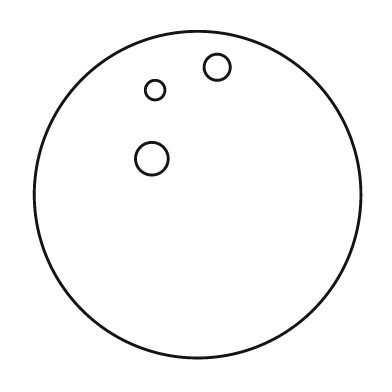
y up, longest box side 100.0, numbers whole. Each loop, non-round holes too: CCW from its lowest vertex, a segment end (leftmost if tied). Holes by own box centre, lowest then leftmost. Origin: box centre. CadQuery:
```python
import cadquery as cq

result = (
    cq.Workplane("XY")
    .moveTo(0.0, 0.0)
    .circle(50.0)
    .moveTo(-14.0, 11.0)
    .circle(5.0)
    .moveTo(-13.0, 32.0)
    .circle(3.0)
    .moveTo(6.0, 39.0)
    .circle(4.0)
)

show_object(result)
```